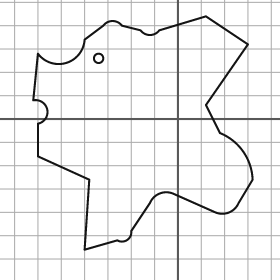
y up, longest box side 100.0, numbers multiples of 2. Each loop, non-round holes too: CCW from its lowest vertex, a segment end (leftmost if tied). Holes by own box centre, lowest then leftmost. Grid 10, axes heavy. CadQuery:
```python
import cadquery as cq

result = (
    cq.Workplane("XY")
    .moveTo(-40.0, -56.0)
    .lineTo(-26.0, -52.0)
    .threePointArc((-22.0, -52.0), (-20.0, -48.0))
    .lineTo(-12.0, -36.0)
    .threePointArc((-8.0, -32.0), (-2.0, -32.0))
    .lineTo(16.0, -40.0)
    .threePointArc((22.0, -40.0), (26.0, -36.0))
    .lineTo(32.0, -26.0)
    .threePointArc((28.0, -14.0), (18.0, -6.0))
    .lineTo(12.0, 6.0)
    .lineTo(30.0, 32.0)
    .lineTo(12.0, 44.0)
    .lineTo(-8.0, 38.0)
    .threePointArc((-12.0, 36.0), (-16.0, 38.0))
    .lineTo(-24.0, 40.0)
    .threePointArc((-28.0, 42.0), (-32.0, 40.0))
    .lineTo(-40.0, 34.0)
    .threePointArc((-48.0, 24.0), (-60.0, 28.0))
    .lineTo(-62.0, 8.0)
    .threePointArc((-56.0, 4.0), (-60.0, -2.0))
    .lineTo(-60.0, -16.0)
    .lineTo(-38.0, -26.0)
    .close()
    .moveTo(-34.0, 26.0)
    .circle(2.0)
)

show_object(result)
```